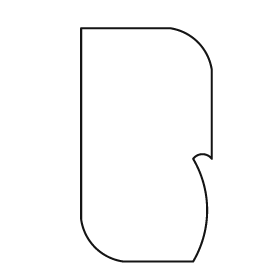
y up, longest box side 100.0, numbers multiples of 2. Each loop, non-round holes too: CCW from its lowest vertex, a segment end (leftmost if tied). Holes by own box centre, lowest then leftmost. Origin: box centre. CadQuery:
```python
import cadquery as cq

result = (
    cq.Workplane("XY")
    .moveTo(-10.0, -50.0)
    .lineTo(20.0, -50.0)
    .threePointArc((26.0, -28.0), (20.0, -6.0))
    .threePointArc((24.0, -4.0), (28.0, -6.0))
    .lineTo(28.0, 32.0)
    .threePointArc((22.0, 44.0), (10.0, 50.0))
    .lineTo(-28.0, 50.0)
    .lineTo(-28.0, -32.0)
    .threePointArc((-22.0, -44.0), (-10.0, -50.0))
    .close()
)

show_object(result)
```